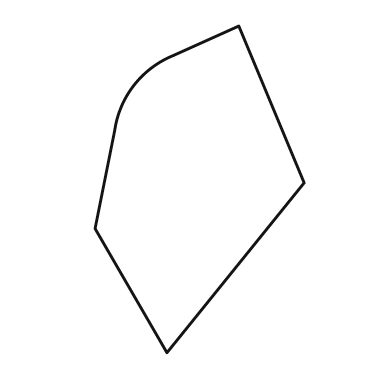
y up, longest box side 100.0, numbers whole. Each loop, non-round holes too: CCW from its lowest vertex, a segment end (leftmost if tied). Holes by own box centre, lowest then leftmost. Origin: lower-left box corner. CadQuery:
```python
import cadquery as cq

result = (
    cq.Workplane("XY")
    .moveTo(22.0, 0.0)
    .lineTo(64.0, 52.0)
    .lineTo(44.0, 100.0)
    .lineTo(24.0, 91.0)
    .threePointArc((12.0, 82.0), (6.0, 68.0))
    .lineTo(0.0, 38.0)
    .close()
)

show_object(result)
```